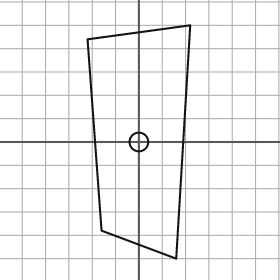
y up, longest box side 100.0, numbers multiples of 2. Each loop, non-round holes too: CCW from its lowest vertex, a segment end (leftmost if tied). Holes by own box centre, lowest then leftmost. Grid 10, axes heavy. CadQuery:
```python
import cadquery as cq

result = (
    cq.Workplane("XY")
    .moveTo(16.0, -50.0)
    .lineTo(22.0, 50.0)
    .lineTo(-22.0, 44.0)
    .lineTo(-16.0, -38.0)
    .close()
    .moveTo(0.0, 0.0)
    .circle(4.0)
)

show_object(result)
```